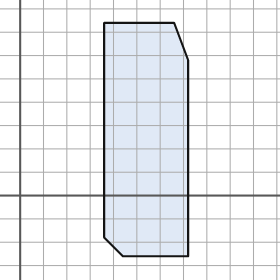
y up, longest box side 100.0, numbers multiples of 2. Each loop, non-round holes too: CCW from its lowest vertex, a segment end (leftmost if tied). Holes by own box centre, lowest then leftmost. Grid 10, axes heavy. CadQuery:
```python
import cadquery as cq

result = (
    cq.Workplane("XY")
    .moveTo(44.0, -26.0)
    .lineTo(72.0, -26.0)
    .lineTo(72.0, 58.0)
    .lineTo(66.0, 74.0)
    .lineTo(36.0, 74.0)
    .lineTo(36.0, -18.0)
    .close()
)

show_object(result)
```